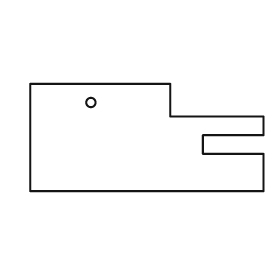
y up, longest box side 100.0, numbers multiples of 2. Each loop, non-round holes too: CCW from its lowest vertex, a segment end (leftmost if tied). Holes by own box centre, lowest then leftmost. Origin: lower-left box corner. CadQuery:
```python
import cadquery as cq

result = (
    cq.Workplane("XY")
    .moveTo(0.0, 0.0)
    .lineTo(100.0, 0.0)
    .lineTo(100.0, 16.0)
    .lineTo(74.0, 16.0)
    .lineTo(74.0, 24.0)
    .lineTo(100.0, 24.0)
    .lineTo(100.0, 32.0)
    .lineTo(60.0, 32.0)
    .lineTo(60.0, 46.0)
    .lineTo(0.0, 46.0)
    .close()
    .moveTo(26.0, 38.0)
    .circle(2.0)
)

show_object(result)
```